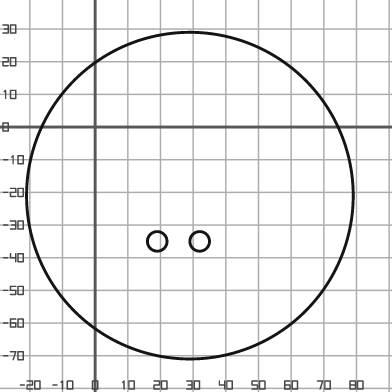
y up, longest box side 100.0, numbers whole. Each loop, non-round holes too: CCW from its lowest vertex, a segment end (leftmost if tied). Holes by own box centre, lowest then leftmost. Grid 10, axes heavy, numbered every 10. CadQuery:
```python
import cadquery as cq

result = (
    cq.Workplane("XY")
    .moveTo(29.0, -21.0)
    .circle(50.0)
    .moveTo(19.0, -35.0)
    .circle(3.0)
    .moveTo(32.0, -35.0)
    .circle(3.0)
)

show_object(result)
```